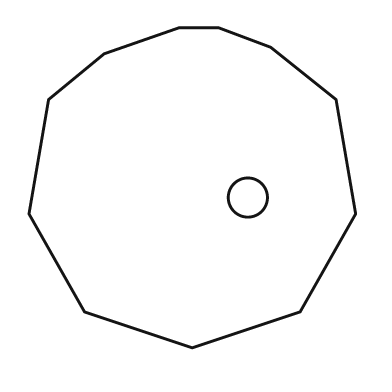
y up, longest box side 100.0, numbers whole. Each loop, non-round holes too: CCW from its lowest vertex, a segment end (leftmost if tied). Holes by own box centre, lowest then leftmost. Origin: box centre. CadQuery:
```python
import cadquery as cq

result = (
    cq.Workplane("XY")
    .moveTo(0.0, -49.0)
    .lineTo(33.0, -38.0)
    .lineTo(50.0, -8.0)
    .lineTo(44.0, 27.0)
    .lineTo(24.0, 43.0)
    .lineTo(8.0, 49.0)
    .lineTo(-4.0, 49.0)
    .lineTo(-27.0, 41.0)
    .lineTo(-44.0, 27.0)
    .lineTo(-50.0, -8.0)
    .lineTo(-33.0, -38.0)
    .close()
    .moveTo(17.0, -3.0)
    .circle(6.0)
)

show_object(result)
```